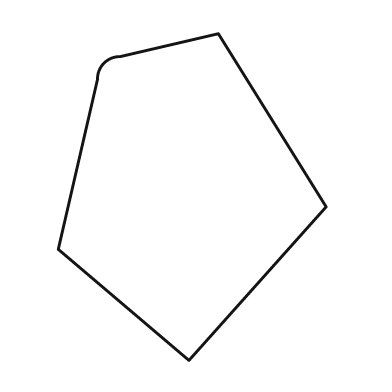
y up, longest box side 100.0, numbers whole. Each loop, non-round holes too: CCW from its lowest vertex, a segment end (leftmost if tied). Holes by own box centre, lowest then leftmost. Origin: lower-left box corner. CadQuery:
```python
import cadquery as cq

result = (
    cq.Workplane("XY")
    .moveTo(40.0, 0.0)
    .lineTo(82.0, 47.0)
    .lineTo(49.0, 100.0)
    .lineTo(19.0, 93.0)
    .threePointArc((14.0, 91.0), (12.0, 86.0))
    .lineTo(0.0, 34.0)
    .close()
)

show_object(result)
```